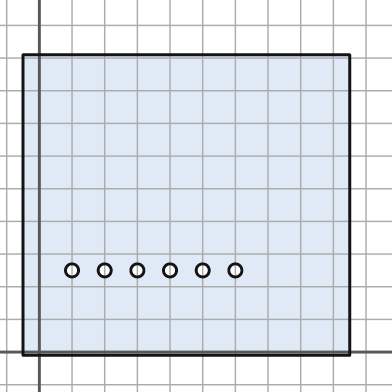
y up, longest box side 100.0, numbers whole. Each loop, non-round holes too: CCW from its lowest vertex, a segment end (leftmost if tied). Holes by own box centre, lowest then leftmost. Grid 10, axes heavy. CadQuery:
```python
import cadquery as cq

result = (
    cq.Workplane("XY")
    .moveTo(-5.0, -1.0)
    .lineTo(95.0, -1.0)
    .lineTo(95.0, 91.0)
    .lineTo(-5.0, 91.0)
    .close()
    .moveTo(10.0, 25.0)
    .circle(2.0)
    .moveTo(20.0, 25.0)
    .circle(2.0)
    .moveTo(30.0, 25.0)
    .circle(2.0)
    .moveTo(40.0, 25.0)
    .circle(2.0)
    .moveTo(50.0, 25.0)
    .circle(2.0)
    .moveTo(60.0, 25.0)
    .circle(2.0)
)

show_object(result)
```